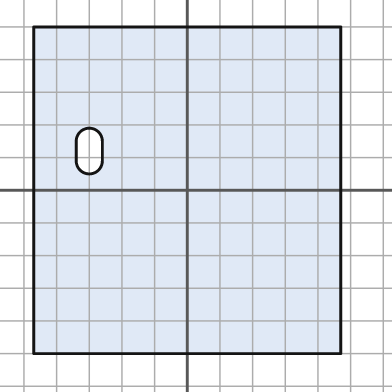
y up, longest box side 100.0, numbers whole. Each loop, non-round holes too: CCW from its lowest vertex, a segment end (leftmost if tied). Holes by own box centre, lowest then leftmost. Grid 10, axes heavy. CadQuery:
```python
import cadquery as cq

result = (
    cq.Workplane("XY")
    .moveTo(-47.0, -50.0)
    .lineTo(47.0, -50.0)
    .lineTo(47.0, 50.0)
    .lineTo(-47.0, 50.0)
    .close()
    .moveTo(-34.0, 9.0)
    .threePointArc((-30.0, 5.0), (-26.0, 9.0))
    .lineTo(-26.0, 15.0)
    .threePointArc((-30.0, 19.0), (-34.0, 15.0))
    .close()
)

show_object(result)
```